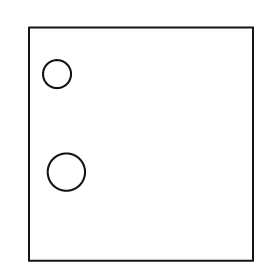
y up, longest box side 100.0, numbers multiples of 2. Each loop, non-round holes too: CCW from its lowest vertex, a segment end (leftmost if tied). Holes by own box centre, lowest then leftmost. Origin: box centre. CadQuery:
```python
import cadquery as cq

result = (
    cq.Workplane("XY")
    .moveTo(-48.0, -50.0)
    .lineTo(48.0, -50.0)
    .lineTo(48.0, 50.0)
    .lineTo(-48.0, 50.0)
    .close()
    .moveTo(-32.0, -12.0)
    .circle(8.0)
    .moveTo(-36.0, 30.0)
    .circle(6.0)
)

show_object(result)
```